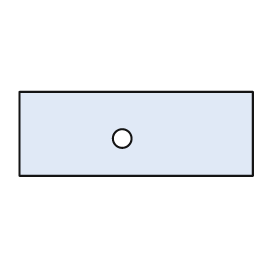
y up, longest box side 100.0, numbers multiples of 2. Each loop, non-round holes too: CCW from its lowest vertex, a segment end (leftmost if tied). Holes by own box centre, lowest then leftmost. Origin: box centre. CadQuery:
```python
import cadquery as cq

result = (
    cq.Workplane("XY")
    .moveTo(-50.0, -18.0)
    .lineTo(50.0, -18.0)
    .lineTo(50.0, 18.0)
    .lineTo(-50.0, 18.0)
    .close()
    .moveTo(-6.0, -2.0)
    .circle(4.0)
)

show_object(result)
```